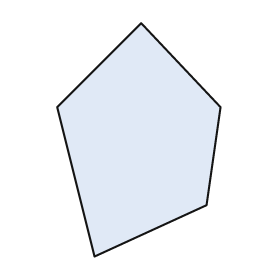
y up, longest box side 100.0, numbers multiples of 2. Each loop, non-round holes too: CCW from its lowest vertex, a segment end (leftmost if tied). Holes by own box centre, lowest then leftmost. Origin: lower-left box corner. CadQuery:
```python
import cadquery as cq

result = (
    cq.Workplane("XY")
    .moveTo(16.0, 0.0)
    .lineTo(64.0, 22.0)
    .lineTo(70.0, 64.0)
    .lineTo(36.0, 100.0)
    .lineTo(0.0, 64.0)
    .close()
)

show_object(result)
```